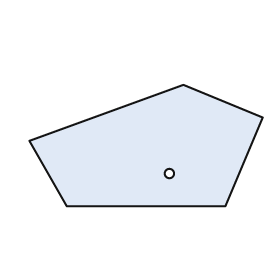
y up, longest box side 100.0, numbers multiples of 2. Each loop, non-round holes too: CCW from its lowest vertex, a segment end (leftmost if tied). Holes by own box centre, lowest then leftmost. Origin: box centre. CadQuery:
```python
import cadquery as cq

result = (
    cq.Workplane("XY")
    .moveTo(-34.0, -26.0)
    .lineTo(34.0, -26.0)
    .lineTo(50.0, 12.0)
    .lineTo(16.0, 26.0)
    .lineTo(-50.0, 2.0)
    .close()
    .moveTo(10.0, -12.0)
    .circle(2.0)
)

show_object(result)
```